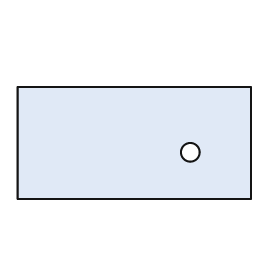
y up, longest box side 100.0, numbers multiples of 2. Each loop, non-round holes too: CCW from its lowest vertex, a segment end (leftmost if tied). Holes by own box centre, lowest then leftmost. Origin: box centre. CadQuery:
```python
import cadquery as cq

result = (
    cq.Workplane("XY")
    .moveTo(-50.0, -24.0)
    .lineTo(50.0, -24.0)
    .lineTo(50.0, 24.0)
    .lineTo(-50.0, 24.0)
    .close()
    .moveTo(24.0, -4.0)
    .circle(4.0)
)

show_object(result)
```